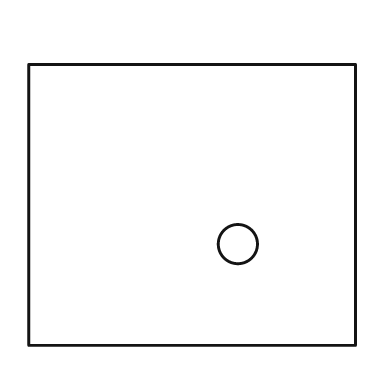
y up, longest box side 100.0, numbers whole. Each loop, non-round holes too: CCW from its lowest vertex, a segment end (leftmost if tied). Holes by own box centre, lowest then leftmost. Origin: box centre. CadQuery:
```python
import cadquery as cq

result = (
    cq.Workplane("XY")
    .moveTo(-50.0, -43.0)
    .lineTo(50.0, -43.0)
    .lineTo(50.0, 43.0)
    .lineTo(-50.0, 43.0)
    .close()
    .moveTo(14.0, -12.0)
    .circle(6.0)
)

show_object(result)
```